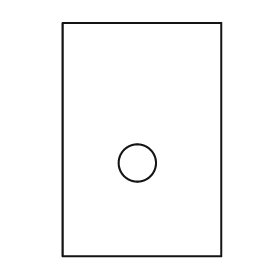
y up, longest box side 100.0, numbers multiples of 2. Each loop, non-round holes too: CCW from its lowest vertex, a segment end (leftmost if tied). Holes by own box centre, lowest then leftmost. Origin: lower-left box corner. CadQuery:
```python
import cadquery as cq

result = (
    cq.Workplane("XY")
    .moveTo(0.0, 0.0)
    .lineTo(68.0, 0.0)
    .lineTo(68.0, 100.0)
    .lineTo(0.0, 100.0)
    .close()
    .moveTo(32.0, 40.0)
    .circle(8.0)
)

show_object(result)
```